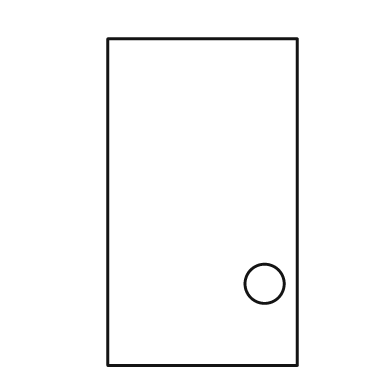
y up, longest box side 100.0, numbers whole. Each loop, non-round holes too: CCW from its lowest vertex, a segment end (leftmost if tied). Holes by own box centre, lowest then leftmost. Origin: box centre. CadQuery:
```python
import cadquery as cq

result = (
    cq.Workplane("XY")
    .moveTo(-29.0, -50.0)
    .lineTo(29.0, -50.0)
    .lineTo(29.0, 50.0)
    .lineTo(-29.0, 50.0)
    .close()
    .moveTo(19.0, -25.0)
    .circle(6.0)
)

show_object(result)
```